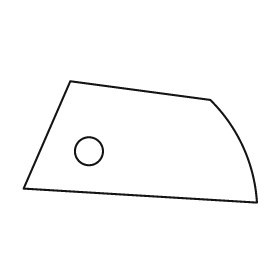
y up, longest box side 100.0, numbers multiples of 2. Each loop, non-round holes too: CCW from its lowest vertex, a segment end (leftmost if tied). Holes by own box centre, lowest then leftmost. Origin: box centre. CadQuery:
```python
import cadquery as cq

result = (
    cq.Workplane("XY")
    .moveTo(50.0, -26.0)
    .threePointArc((44.0, -2.0), (30.0, 18.0))
    .lineTo(-30.0, 26.0)
    .lineTo(-50.0, -20.0)
    .close()
    .moveTo(-22.0, -4.0)
    .circle(6.0)
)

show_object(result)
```